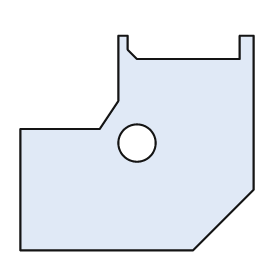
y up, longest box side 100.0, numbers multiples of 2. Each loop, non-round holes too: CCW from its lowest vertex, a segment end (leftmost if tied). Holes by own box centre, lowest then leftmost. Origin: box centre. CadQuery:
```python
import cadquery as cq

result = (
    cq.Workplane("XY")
    .moveTo(-50.0, -46.0)
    .lineTo(24.0, -46.0)
    .lineTo(50.0, -20.0)
    .lineTo(50.0, 46.0)
    .lineTo(44.0, 46.0)
    .lineTo(44.0, 36.0)
    .lineTo(0.0, 36.0)
    .lineTo(-4.0, 40.0)
    .lineTo(-4.0, 46.0)
    .lineTo(-8.0, 46.0)
    .lineTo(-8.0, 18.0)
    .lineTo(-16.0, 6.0)
    .lineTo(-50.0, 6.0)
    .close()
    .moveTo(0.0, 0.0)
    .circle(8.0)
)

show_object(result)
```